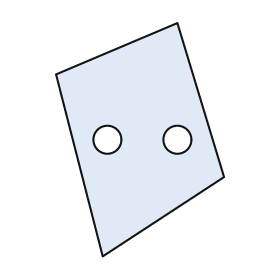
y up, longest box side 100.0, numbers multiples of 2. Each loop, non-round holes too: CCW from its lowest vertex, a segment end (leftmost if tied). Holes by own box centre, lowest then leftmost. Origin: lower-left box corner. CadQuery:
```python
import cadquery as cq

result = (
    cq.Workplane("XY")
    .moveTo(20.0, 0.0)
    .lineTo(72.0, 34.0)
    .lineTo(52.0, 100.0)
    .lineTo(0.0, 78.0)
    .close()
    .moveTo(22.0, 50.0)
    .circle(6.0)
    .moveTo(52.0, 50.0)
    .circle(6.0)
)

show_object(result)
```